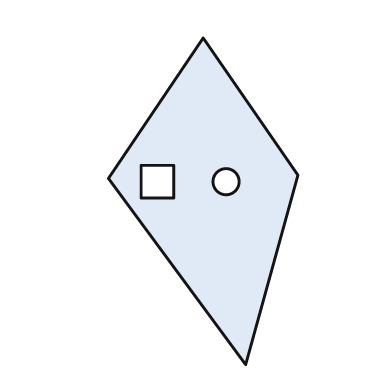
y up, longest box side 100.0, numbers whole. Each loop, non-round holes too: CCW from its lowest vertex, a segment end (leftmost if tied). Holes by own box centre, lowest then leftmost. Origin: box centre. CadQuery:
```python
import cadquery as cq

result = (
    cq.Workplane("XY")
    .moveTo(13.0, -50.0)
    .lineTo(29.0, 8.0)
    .lineTo(0.0, 50.0)
    .lineTo(-29.0, 7.0)
    .close()
    .moveTo(-19.0, 1.0)
    .lineTo(-9.0, 1.0)
    .lineTo(-9.0, 11.0)
    .lineTo(-19.0, 11.0)
    .close()
    .moveTo(7.0, 6.0)
    .circle(4.0)
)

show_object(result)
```